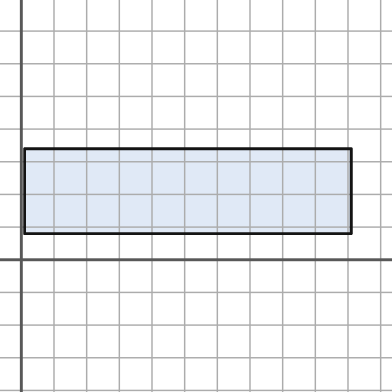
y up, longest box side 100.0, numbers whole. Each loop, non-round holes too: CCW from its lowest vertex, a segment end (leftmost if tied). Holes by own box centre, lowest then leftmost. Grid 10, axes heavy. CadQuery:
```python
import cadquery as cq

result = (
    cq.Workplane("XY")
    .moveTo(1.0, 8.0)
    .lineTo(101.0, 8.0)
    .lineTo(101.0, 34.0)
    .lineTo(1.0, 34.0)
    .close()
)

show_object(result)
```